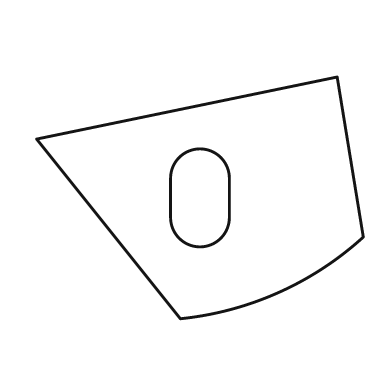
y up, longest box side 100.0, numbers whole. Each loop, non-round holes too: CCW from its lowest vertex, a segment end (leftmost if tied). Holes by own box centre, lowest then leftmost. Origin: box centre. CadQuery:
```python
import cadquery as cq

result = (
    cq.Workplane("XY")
    .moveTo(-6.0, -37.0)
    .threePointArc((24.0, -29.0), (50.0, -12.0))
    .lineTo(42.0, 37.0)
    .lineTo(-50.0, 18.0)
    .close()
    .moveTo(-9.0, -6.0)
    .threePointArc((0.0, -15.0), (9.0, -6.0))
    .lineTo(9.0, 6.0)
    .threePointArc((0.0, 15.0), (-9.0, 6.0))
    .close()
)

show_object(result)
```